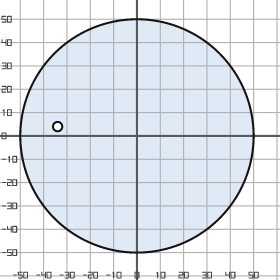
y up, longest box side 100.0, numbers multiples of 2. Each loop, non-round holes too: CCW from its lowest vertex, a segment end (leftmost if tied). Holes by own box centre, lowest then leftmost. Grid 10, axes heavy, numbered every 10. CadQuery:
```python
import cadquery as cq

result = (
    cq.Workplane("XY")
    .moveTo(0.0, 0.0)
    .circle(50.0)
    .moveTo(-34.0, 4.0)
    .circle(2.0)
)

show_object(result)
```